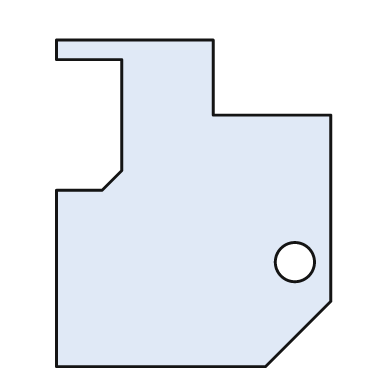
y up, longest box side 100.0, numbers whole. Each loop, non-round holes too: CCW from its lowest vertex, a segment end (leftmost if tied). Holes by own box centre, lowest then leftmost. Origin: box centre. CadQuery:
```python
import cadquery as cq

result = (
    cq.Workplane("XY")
    .moveTo(-42.0, -50.0)
    .lineTo(22.0, -50.0)
    .lineTo(42.0, -30.0)
    .lineTo(42.0, 27.0)
    .lineTo(6.0, 27.0)
    .lineTo(6.0, 50.0)
    .lineTo(-42.0, 50.0)
    .lineTo(-42.0, 44.0)
    .lineTo(-22.0, 44.0)
    .lineTo(-22.0, 10.0)
    .lineTo(-28.0, 4.0)
    .lineTo(-42.0, 4.0)
    .close()
    .moveTo(31.0, -18.0)
    .circle(6.0)
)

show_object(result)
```